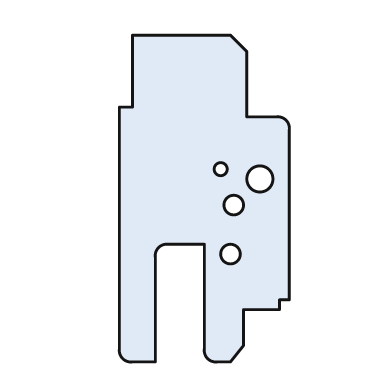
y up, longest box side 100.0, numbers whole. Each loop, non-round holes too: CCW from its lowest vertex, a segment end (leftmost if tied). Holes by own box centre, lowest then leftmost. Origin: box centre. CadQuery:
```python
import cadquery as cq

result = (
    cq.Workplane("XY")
    .moveTo(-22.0, -50.0)
    .lineTo(-15.0, -50.0)
    .lineTo(-15.0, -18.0)
    .threePointArc((-14.0, -15.0), (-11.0, -14.0))
    .lineTo(0.0, -14.0)
    .lineTo(0.0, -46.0)
    .threePointArc((1.0, -49.0), (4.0, -50.0))
    .lineTo(8.0, -50.0)
    .lineTo(12.0, -45.0)
    .lineTo(12.0, -34.0)
    .lineTo(23.0, -34.0)
    .lineTo(23.0, -31.0)
    .lineTo(26.0, -31.0)
    .lineTo(26.0, 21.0)
    .threePointArc((25.0, 24.0), (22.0, 25.0))
    .lineTo(13.0, 25.0)
    .lineTo(13.0, 45.0)
    .lineTo(8.0, 50.0)
    .lineTo(-22.0, 50.0)
    .lineTo(-22.0, 28.0)
    .lineTo(-26.0, 28.0)
    .lineTo(-26.0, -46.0)
    .threePointArc((-25.0, -49.0), (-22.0, -50.0))
    .close()
    .moveTo(8.0, -17.0)
    .circle(3.0)
    .moveTo(9.0, -2.0)
    .circle(3.0)
    .moveTo(17.0, 6.0)
    .circle(4.0)
    .moveTo(5.0, 9.0)
    .circle(2.0)
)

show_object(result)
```